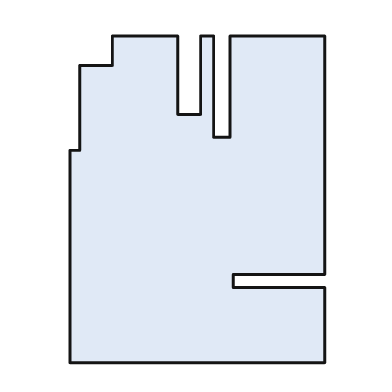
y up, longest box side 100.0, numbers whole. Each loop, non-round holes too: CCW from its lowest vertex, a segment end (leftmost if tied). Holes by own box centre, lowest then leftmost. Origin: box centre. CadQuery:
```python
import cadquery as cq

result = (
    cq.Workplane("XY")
    .moveTo(-39.0, -50.0)
    .lineTo(39.0, -50.0)
    .lineTo(39.0, -27.0)
    .lineTo(11.0, -27.0)
    .lineTo(11.0, -23.0)
    .lineTo(39.0, -23.0)
    .lineTo(39.0, 50.0)
    .lineTo(10.0, 50.0)
    .lineTo(10.0, 19.0)
    .lineTo(5.0, 19.0)
    .lineTo(5.0, 50.0)
    .lineTo(1.0, 50.0)
    .lineTo(1.0, 26.0)
    .lineTo(-6.0, 26.0)
    .lineTo(-6.0, 50.0)
    .lineTo(-26.0, 50.0)
    .lineTo(-26.0, 41.0)
    .lineTo(-36.0, 41.0)
    .lineTo(-36.0, 15.0)
    .lineTo(-39.0, 15.0)
    .close()
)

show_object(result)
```